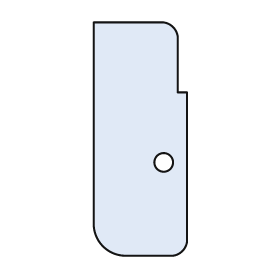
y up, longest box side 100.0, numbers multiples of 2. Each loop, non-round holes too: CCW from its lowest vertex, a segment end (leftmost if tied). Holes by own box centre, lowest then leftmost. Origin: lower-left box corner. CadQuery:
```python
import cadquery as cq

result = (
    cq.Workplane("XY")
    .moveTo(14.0, 0.0)
    .lineTo(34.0, 0.0)
    .threePointArc((38.0, 2.0), (40.0, 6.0))
    .lineTo(40.0, 70.0)
    .lineTo(36.0, 70.0)
    .lineTo(36.0, 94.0)
    .threePointArc((34.0, 98.0), (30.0, 100.0))
    .lineTo(0.0, 100.0)
    .lineTo(0.0, 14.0)
    .threePointArc((4.0, 4.0), (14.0, 0.0))
    .close()
    .moveTo(30.0, 40.0)
    .circle(4.0)
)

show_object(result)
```